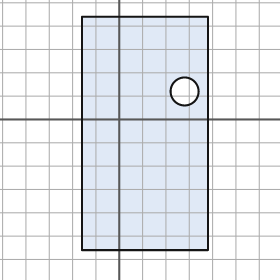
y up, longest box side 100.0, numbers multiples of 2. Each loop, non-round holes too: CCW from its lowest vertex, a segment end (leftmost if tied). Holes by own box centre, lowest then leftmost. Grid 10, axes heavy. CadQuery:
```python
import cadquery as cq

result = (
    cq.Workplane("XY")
    .moveTo(-16.0, -56.0)
    .lineTo(38.0, -56.0)
    .lineTo(38.0, 44.0)
    .lineTo(-16.0, 44.0)
    .close()
    .moveTo(28.0, 12.0)
    .circle(6.0)
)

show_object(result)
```